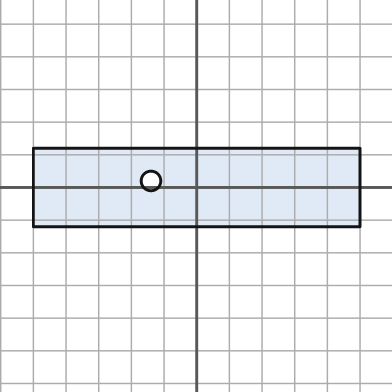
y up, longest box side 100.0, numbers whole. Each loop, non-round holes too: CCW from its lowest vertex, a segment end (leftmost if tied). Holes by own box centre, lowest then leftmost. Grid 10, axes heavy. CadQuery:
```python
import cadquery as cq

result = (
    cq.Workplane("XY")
    .moveTo(-50.0, -12.0)
    .lineTo(50.0, -12.0)
    .lineTo(50.0, 12.0)
    .lineTo(-50.0, 12.0)
    .close()
    .moveTo(-14.0, 2.0)
    .circle(3.0)
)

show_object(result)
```